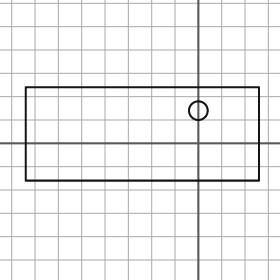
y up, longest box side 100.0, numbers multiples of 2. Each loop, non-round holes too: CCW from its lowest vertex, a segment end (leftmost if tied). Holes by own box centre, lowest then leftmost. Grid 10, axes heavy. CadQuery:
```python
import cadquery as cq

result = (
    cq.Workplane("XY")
    .moveTo(-74.0, -16.0)
    .lineTo(26.0, -16.0)
    .lineTo(26.0, 24.0)
    .lineTo(-74.0, 24.0)
    .close()
    .moveTo(0.0, 14.0)
    .circle(4.0)
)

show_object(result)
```